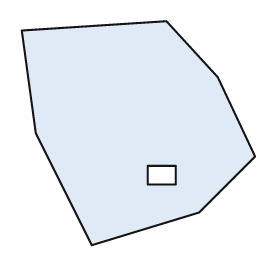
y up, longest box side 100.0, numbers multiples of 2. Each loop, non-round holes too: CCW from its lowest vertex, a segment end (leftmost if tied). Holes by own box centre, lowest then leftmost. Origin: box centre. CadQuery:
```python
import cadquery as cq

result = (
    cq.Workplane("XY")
    .moveTo(-20.0, -48.0)
    .lineTo(26.0, -34.0)
    .lineTo(50.0, -10.0)
    .lineTo(34.0, 24.0)
    .lineTo(12.0, 48.0)
    .lineTo(-50.0, 44.0)
    .lineTo(-44.0, 0.0)
    .close()
    .moveTo(4.0, -22.0)
    .lineTo(16.0, -22.0)
    .lineTo(16.0, -14.0)
    .lineTo(4.0, -14.0)
    .close()
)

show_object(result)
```